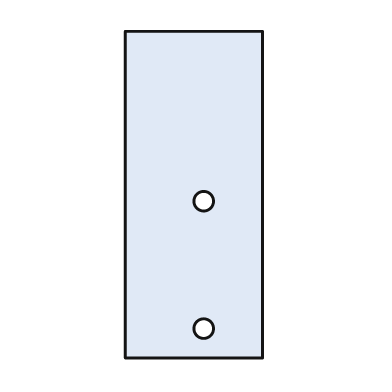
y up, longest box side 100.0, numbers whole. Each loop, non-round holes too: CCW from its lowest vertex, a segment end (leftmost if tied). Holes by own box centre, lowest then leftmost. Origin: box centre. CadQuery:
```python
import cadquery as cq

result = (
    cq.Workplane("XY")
    .moveTo(-21.0, -50.0)
    .lineTo(21.0, -50.0)
    .lineTo(21.0, 50.0)
    .lineTo(-21.0, 50.0)
    .close()
    .moveTo(3.0, -41.0)
    .circle(3.0)
    .moveTo(3.0, -2.0)
    .circle(3.0)
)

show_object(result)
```